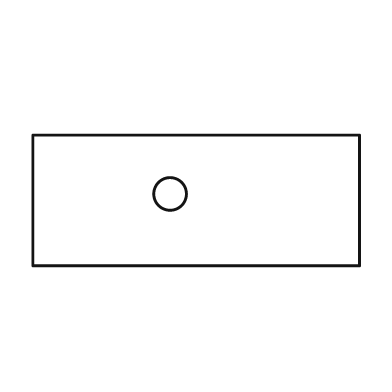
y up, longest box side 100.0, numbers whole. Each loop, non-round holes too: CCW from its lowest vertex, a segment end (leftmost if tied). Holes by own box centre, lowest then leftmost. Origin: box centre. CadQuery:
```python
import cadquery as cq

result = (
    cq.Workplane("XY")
    .moveTo(-50.0, -20.0)
    .lineTo(50.0, -20.0)
    .lineTo(50.0, 20.0)
    .lineTo(-50.0, 20.0)
    .close()
    .moveTo(-8.0, 2.0)
    .circle(5.0)
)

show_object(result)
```